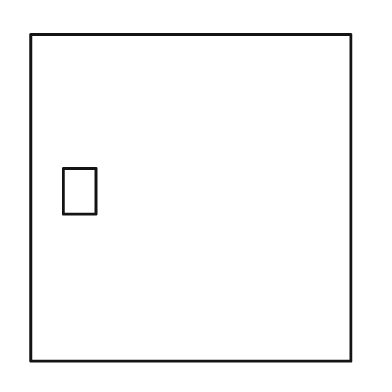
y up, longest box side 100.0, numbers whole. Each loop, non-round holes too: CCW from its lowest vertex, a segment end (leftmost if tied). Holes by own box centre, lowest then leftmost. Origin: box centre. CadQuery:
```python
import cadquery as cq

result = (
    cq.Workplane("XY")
    .moveTo(-49.0, -50.0)
    .lineTo(49.0, -50.0)
    .lineTo(49.0, 50.0)
    .lineTo(-49.0, 50.0)
    .close()
    .moveTo(-39.0, -5.0)
    .lineTo(-29.0, -5.0)
    .lineTo(-29.0, 9.0)
    .lineTo(-39.0, 9.0)
    .close()
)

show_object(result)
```